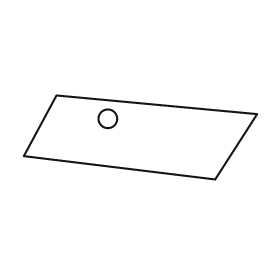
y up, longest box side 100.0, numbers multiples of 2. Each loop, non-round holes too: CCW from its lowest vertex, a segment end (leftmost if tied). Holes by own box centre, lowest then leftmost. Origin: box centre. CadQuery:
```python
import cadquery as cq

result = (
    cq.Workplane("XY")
    .moveTo(32.0, -18.0)
    .lineTo(50.0, 10.0)
    .lineTo(-36.0, 18.0)
    .lineTo(-50.0, -8.0)
    .close()
    .moveTo(-14.0, 8.0)
    .circle(4.0)
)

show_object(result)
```